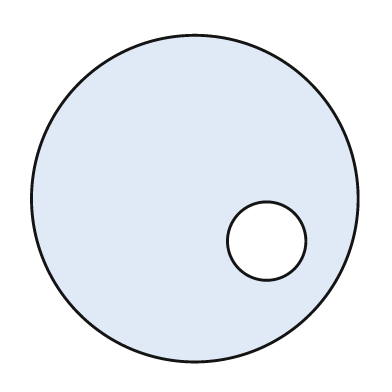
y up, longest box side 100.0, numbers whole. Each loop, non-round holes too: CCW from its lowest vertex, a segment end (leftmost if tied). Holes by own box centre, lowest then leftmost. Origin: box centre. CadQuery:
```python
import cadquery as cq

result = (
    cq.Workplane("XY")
    .moveTo(0.0, 0.0)
    .circle(50.0)
    .moveTo(22.0, -13.0)
    .circle(12.0)
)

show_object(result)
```